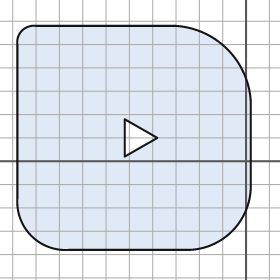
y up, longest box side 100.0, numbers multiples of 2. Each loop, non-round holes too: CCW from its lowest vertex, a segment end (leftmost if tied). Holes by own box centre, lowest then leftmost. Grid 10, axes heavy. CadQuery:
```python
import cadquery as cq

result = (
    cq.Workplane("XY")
    .moveTo(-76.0, -38.0)
    .lineTo(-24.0, -38.0)
    .threePointArc((-6.0, -30.0), (2.0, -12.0))
    .lineTo(2.0, 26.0)
    .threePointArc((-8.0, 48.0), (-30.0, 58.0))
    .lineTo(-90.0, 58.0)
    .threePointArc((-96.0, 56.0), (-98.0, 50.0))
    .lineTo(-98.0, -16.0)
    .threePointArc((-92.0, -32.0), (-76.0, -38.0))
    .close()
    .moveTo(-52.0, 2.0)
    .lineTo(-38.0, 10.0)
    .lineTo(-52.0, 18.0)
    .close()
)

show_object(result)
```